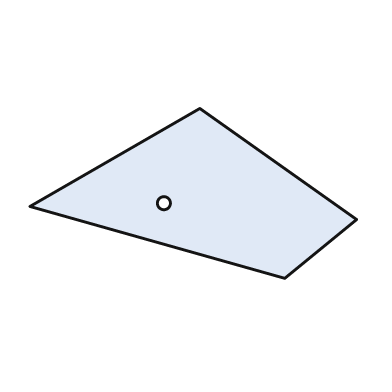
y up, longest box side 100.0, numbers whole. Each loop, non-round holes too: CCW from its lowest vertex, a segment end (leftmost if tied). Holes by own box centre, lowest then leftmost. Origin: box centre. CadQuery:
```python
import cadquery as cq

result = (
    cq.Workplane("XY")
    .moveTo(28.0, -26.0)
    .lineTo(50.0, -8.0)
    .lineTo(2.0, 26.0)
    .lineTo(-50.0, -4.0)
    .close()
    .moveTo(-9.0, -3.0)
    .circle(2.0)
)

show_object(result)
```